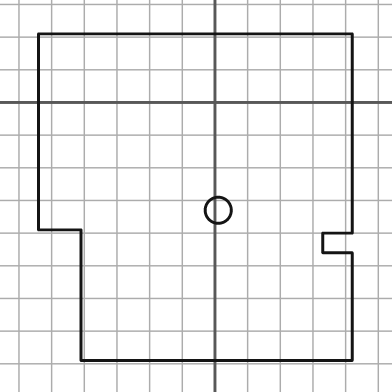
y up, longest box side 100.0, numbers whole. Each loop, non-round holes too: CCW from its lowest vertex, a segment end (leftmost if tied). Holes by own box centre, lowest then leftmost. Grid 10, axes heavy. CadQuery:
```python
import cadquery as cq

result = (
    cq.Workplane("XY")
    .moveTo(-41.0, -79.0)
    .lineTo(42.0, -79.0)
    .lineTo(42.0, -46.0)
    .lineTo(33.0, -46.0)
    .lineTo(33.0, -40.0)
    .lineTo(42.0, -40.0)
    .lineTo(42.0, 21.0)
    .lineTo(-54.0, 21.0)
    .lineTo(-54.0, -39.0)
    .lineTo(-41.0, -39.0)
    .close()
    .moveTo(1.0, -33.0)
    .circle(4.0)
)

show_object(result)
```